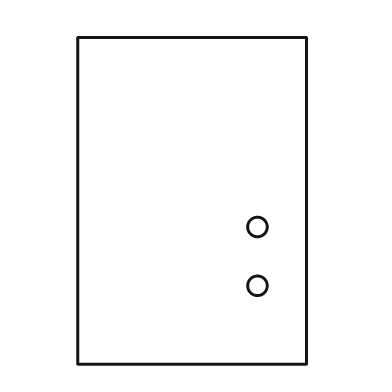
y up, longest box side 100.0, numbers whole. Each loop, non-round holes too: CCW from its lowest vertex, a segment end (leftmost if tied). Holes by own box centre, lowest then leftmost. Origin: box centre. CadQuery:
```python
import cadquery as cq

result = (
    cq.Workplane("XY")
    .moveTo(-35.0, -50.0)
    .lineTo(35.0, -50.0)
    .lineTo(35.0, 50.0)
    .lineTo(-35.0, 50.0)
    .close()
    .moveTo(20.0, -26.0)
    .circle(3.0)
    .moveTo(20.0, -8.0)
    .circle(3.0)
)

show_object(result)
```